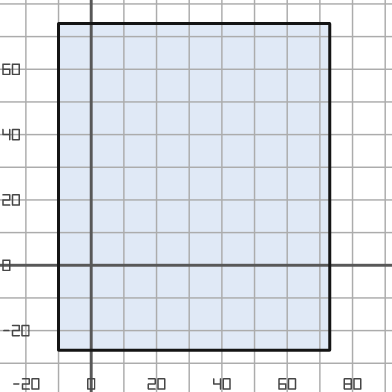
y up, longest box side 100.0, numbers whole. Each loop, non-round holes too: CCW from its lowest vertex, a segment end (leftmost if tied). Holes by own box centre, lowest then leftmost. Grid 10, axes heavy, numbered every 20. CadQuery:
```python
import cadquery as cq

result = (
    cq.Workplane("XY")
    .moveTo(-10.0, -26.0)
    .lineTo(73.0, -26.0)
    .lineTo(73.0, 74.0)
    .lineTo(-10.0, 74.0)
    .close()
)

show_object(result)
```